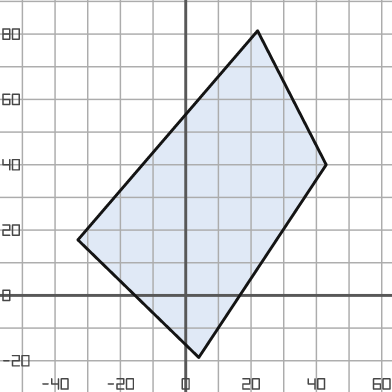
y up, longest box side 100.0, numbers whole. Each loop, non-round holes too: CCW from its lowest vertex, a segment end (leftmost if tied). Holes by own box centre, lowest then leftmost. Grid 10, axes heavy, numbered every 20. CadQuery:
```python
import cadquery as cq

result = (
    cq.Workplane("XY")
    .moveTo(4.0, -19.0)
    .lineTo(43.0, 40.0)
    .lineTo(22.0, 81.0)
    .lineTo(-33.0, 17.0)
    .close()
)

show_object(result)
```